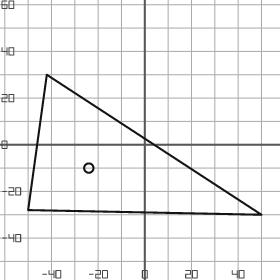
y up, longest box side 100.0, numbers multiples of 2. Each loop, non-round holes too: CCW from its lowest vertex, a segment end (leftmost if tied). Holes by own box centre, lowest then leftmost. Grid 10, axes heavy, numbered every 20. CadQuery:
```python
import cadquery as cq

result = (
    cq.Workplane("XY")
    .moveTo(50.0, -30.0)
    .lineTo(-42.0, 30.0)
    .lineTo(-50.0, -28.0)
    .close()
    .moveTo(-24.0, -10.0)
    .circle(2.0)
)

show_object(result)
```